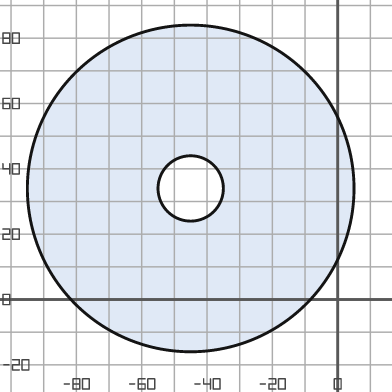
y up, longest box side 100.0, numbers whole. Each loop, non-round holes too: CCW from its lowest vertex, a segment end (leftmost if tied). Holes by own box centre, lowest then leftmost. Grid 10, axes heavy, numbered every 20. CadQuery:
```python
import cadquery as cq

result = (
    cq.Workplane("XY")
    .moveTo(-45.0, 34.0)
    .circle(50.0)
    .moveTo(-45.0, 34.0)
    .circle(10.0)
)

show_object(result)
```